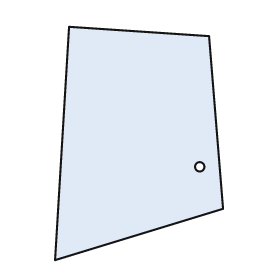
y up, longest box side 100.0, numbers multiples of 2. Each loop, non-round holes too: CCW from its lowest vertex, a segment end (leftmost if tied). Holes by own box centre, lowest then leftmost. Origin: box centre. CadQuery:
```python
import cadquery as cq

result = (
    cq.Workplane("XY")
    .moveTo(-36.0, -50.0)
    .lineTo(36.0, -28.0)
    .lineTo(30.0, 46.0)
    .lineTo(-30.0, 50.0)
    .close()
    .moveTo(26.0, -10.0)
    .circle(2.0)
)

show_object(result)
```